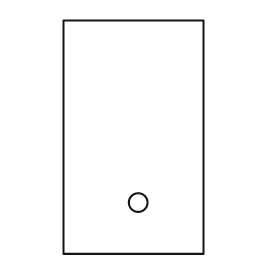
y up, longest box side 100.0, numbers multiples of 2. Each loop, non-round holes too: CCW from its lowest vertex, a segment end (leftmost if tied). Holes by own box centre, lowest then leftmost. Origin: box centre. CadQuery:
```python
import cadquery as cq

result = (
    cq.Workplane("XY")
    .moveTo(-30.0, -50.0)
    .lineTo(30.0, -50.0)
    .lineTo(30.0, 50.0)
    .lineTo(-30.0, 50.0)
    .close()
    .moveTo(2.0, -28.0)
    .circle(4.0)
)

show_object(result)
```